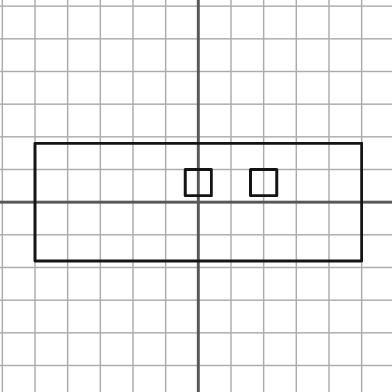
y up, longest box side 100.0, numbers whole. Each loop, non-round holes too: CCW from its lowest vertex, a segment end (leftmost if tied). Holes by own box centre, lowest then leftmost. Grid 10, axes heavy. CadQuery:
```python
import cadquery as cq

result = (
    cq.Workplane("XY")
    .moveTo(-50.0, -18.0)
    .lineTo(50.0, -18.0)
    .lineTo(50.0, 18.0)
    .lineTo(-50.0, 18.0)
    .close()
    .moveTo(-4.0, 2.0)
    .lineTo(4.0, 2.0)
    .lineTo(4.0, 10.0)
    .lineTo(-4.0, 10.0)
    .close()
    .moveTo(16.0, 2.0)
    .lineTo(24.0, 2.0)
    .lineTo(24.0, 10.0)
    .lineTo(16.0, 10.0)
    .close()
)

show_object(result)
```